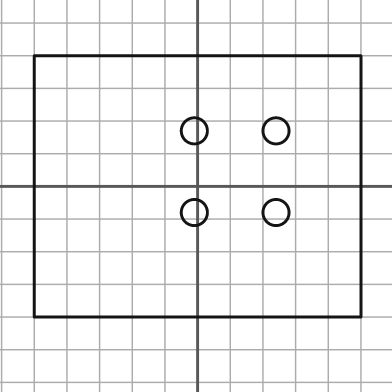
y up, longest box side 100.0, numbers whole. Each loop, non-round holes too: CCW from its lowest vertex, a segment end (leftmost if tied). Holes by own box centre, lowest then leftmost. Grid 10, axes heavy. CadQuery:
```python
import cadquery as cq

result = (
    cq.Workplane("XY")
    .moveTo(-50.0, -40.0)
    .lineTo(50.0, -40.0)
    .lineTo(50.0, 40.0)
    .lineTo(-50.0, 40.0)
    .close()
    .moveTo(-1.0, -8.0)
    .circle(4.0)
    .moveTo(24.0, -8.0)
    .circle(4.0)
    .moveTo(-1.0, 17.0)
    .circle(4.0)
    .moveTo(24.0, 17.0)
    .circle(4.0)
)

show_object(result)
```